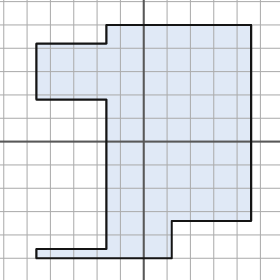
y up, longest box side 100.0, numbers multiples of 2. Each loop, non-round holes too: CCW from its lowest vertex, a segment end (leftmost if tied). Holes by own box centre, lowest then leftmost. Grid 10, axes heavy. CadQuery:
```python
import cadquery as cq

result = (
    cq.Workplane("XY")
    .moveTo(-46.0, -50.0)
    .lineTo(12.0, -50.0)
    .lineTo(12.0, -34.0)
    .lineTo(46.0, -34.0)
    .lineTo(46.0, 50.0)
    .lineTo(-16.0, 50.0)
    .lineTo(-16.0, 42.0)
    .lineTo(-46.0, 42.0)
    .lineTo(-46.0, 18.0)
    .lineTo(-16.0, 18.0)
    .lineTo(-16.0, -46.0)
    .lineTo(-46.0, -46.0)
    .close()
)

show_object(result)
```